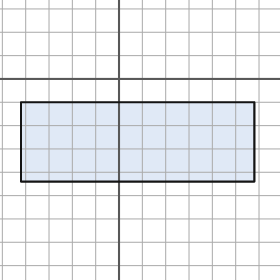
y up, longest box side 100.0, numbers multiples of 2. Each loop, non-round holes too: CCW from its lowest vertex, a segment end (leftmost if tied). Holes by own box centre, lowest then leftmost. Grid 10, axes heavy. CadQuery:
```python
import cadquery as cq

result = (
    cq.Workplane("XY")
    .moveTo(-42.0, -44.0)
    .lineTo(58.0, -44.0)
    .lineTo(58.0, -10.0)
    .lineTo(-42.0, -10.0)
    .close()
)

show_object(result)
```